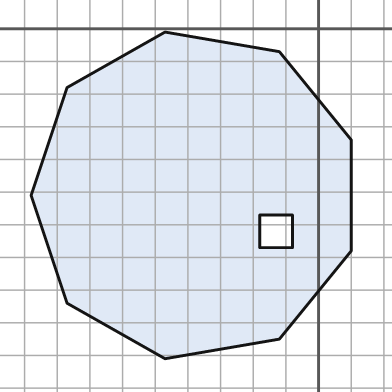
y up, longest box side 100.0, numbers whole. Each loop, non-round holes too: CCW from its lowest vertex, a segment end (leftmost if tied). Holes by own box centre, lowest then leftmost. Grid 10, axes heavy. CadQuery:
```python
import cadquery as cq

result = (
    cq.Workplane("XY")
    .moveTo(-47.0, -101.0)
    .lineTo(-12.0, -95.0)
    .lineTo(10.0, -68.0)
    .lineTo(10.0, -34.0)
    .lineTo(-12.0, -7.0)
    .lineTo(-47.0, -1.0)
    .lineTo(-77.0, -18.0)
    .lineTo(-88.0, -51.0)
    .lineTo(-77.0, -84.0)
    .close()
    .moveTo(-18.0, -67.0)
    .lineTo(-8.0, -67.0)
    .lineTo(-8.0, -57.0)
    .lineTo(-18.0, -57.0)
    .close()
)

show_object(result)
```